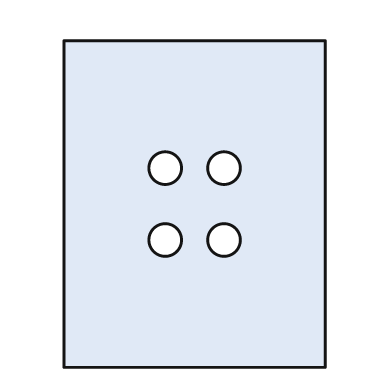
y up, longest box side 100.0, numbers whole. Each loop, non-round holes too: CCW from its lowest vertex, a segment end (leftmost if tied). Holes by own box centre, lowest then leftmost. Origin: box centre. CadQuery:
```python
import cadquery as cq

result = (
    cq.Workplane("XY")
    .moveTo(-40.0, -50.0)
    .lineTo(40.0, -50.0)
    .lineTo(40.0, 50.0)
    .lineTo(-40.0, 50.0)
    .close()
    .moveTo(-9.0, -11.0)
    .circle(5.0)
    .moveTo(9.0, -11.0)
    .circle(5.0)
    .moveTo(-9.0, 11.0)
    .circle(5.0)
    .moveTo(9.0, 11.0)
    .circle(5.0)
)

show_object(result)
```